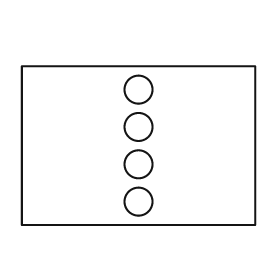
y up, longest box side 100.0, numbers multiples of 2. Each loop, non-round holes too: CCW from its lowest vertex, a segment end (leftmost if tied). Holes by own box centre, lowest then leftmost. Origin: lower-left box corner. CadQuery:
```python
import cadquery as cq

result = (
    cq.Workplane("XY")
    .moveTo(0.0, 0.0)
    .lineTo(100.0, 0.0)
    .lineTo(100.0, 68.0)
    .lineTo(0.0, 68.0)
    .close()
    .moveTo(50.0, 10.0)
    .circle(6.0)
    .moveTo(50.0, 26.0)
    .circle(6.0)
    .moveTo(50.0, 42.0)
    .circle(6.0)
    .moveTo(50.0, 58.0)
    .circle(6.0)
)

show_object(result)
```